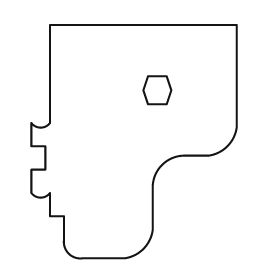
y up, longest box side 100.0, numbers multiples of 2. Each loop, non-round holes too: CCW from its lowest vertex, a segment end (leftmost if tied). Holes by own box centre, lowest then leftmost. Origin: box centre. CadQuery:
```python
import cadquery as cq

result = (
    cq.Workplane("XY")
    .moveTo(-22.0, -50.0)
    .lineTo(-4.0, -50.0)
    .threePointArc((4.0, -46.0), (8.0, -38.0))
    .lineTo(8.0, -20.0)
    .threePointArc((12.0, -10.0), (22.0, -6.0))
    .lineTo(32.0, -6.0)
    .threePointArc((40.0, -2.0), (44.0, 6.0))
    .lineTo(44.0, 50.0)
    .lineTo(-36.0, 50.0)
    .lineTo(-36.0, 8.0)
    .threePointArc((-40.0, 6.0), (-44.0, 8.0))
    .lineTo(-44.0, -2.0)
    .lineTo(-38.0, -2.0)
    .lineTo(-38.0, -12.0)
    .lineTo(-44.0, -12.0)
    .lineTo(-44.0, -22.0)
    .threePointArc((-40.0, -24.0), (-36.0, -22.0))
    .lineTo(-36.0, -32.0)
    .lineTo(-30.0, -32.0)
    .lineTo(-30.0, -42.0)
    .threePointArc((-28.0, -48.0), (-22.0, -50.0))
    .close()
    .moveTo(6.0, 16.0)
    .lineTo(14.0, 16.0)
    .lineTo(16.0, 22.0)
    .lineTo(14.0, 28.0)
    .lineTo(6.0, 28.0)
    .lineTo(4.0, 22.0)
    .close()
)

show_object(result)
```